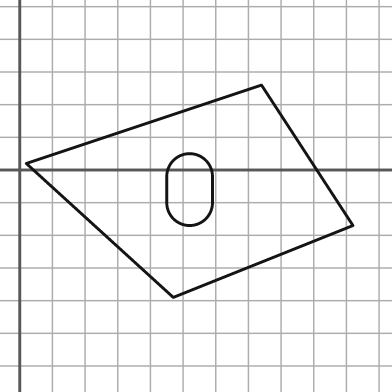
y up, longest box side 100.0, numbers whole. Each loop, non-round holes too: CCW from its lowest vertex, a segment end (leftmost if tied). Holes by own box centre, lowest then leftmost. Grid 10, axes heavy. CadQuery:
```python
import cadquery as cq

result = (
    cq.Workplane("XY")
    .moveTo(47.0, -39.0)
    .lineTo(102.0, -17.0)
    .lineTo(74.0, 26.0)
    .lineTo(2.0, 2.0)
    .close()
    .moveTo(45.0, -10.0)
    .threePointArc((52.0, -17.0), (59.0, -10.0))
    .lineTo(59.0, -2.0)
    .threePointArc((52.0, 5.0), (45.0, -2.0))
    .close()
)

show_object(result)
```